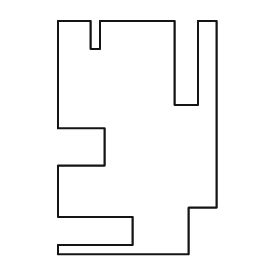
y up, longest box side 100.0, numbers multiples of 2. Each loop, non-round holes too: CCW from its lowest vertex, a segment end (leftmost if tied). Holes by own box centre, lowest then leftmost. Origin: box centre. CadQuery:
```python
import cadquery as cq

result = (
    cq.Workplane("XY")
    .moveTo(-34.0, -50.0)
    .lineTo(22.0, -50.0)
    .lineTo(22.0, -30.0)
    .lineTo(34.0, -30.0)
    .lineTo(34.0, 50.0)
    .lineTo(26.0, 50.0)
    .lineTo(26.0, 14.0)
    .lineTo(16.0, 14.0)
    .lineTo(16.0, 50.0)
    .lineTo(-16.0, 50.0)
    .lineTo(-16.0, 38.0)
    .lineTo(-20.0, 38.0)
    .lineTo(-20.0, 50.0)
    .lineTo(-34.0, 50.0)
    .lineTo(-34.0, 4.0)
    .lineTo(-14.0, 4.0)
    .lineTo(-14.0, -12.0)
    .lineTo(-34.0, -12.0)
    .lineTo(-34.0, -34.0)
    .lineTo(-2.0, -34.0)
    .lineTo(-2.0, -46.0)
    .lineTo(-34.0, -46.0)
    .close()
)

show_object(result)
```